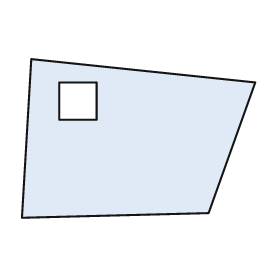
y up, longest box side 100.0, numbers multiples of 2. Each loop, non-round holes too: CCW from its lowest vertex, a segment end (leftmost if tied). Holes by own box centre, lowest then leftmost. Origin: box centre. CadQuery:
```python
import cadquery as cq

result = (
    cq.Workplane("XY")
    .moveTo(-50.0, -34.0)
    .lineTo(30.0, -32.0)
    .lineTo(50.0, 24.0)
    .lineTo(-46.0, 34.0)
    .close()
    .moveTo(-34.0, 8.0)
    .lineTo(-18.0, 8.0)
    .lineTo(-18.0, 24.0)
    .lineTo(-34.0, 24.0)
    .close()
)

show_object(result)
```